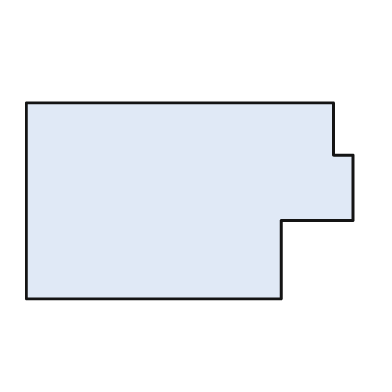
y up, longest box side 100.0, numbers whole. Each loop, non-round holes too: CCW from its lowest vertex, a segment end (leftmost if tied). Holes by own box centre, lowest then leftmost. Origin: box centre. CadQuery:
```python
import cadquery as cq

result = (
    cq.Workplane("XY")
    .moveTo(-50.0, -30.0)
    .lineTo(28.0, -30.0)
    .lineTo(28.0, -6.0)
    .lineTo(50.0, -6.0)
    .lineTo(50.0, 14.0)
    .lineTo(44.0, 14.0)
    .lineTo(44.0, 30.0)
    .lineTo(-50.0, 30.0)
    .close()
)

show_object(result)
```